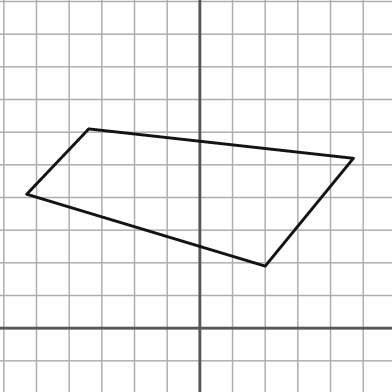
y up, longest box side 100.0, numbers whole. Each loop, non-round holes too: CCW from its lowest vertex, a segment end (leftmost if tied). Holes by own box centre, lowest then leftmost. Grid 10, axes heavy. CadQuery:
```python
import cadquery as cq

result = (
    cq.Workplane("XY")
    .moveTo(20.0, 19.0)
    .lineTo(47.0, 52.0)
    .lineTo(-34.0, 61.0)
    .lineTo(-53.0, 41.0)
    .close()
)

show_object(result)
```